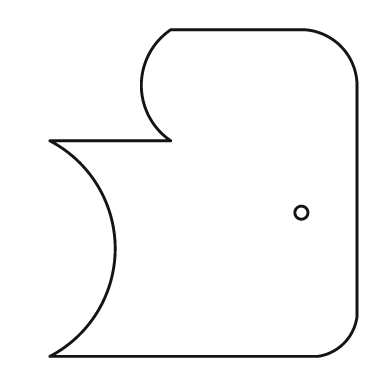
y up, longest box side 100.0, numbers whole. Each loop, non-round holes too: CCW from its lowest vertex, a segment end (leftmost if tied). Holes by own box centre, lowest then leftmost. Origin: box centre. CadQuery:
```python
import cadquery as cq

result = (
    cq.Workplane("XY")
    .moveTo(-47.0, -50.0)
    .lineTo(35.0, -50.0)
    .threePointArc((43.0, -46.0), (47.0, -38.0))
    .lineTo(47.0, 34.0)
    .threePointArc((42.0, 45.0), (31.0, 50.0))
    .lineTo(-10.0, 50.0)
    .threePointArc((-19.0, 33.0), (-10.0, 16.0))
    .lineTo(-47.0, 16.0)
    .threePointArc((-27.0, -17.0), (-47.0, -50.0))
    .close()
    .moveTo(30.0, -6.0)
    .circle(2.0)
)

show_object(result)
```